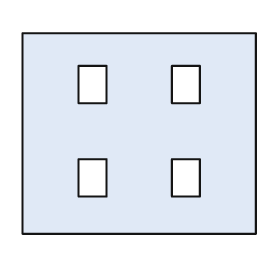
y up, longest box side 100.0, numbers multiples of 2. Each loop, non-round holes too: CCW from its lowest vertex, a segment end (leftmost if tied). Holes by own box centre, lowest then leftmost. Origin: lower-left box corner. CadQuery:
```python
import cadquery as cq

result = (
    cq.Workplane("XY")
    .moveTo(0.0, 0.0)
    .lineTo(100.0, 0.0)
    .lineTo(100.0, 86.0)
    .lineTo(0.0, 86.0)
    .close()
    .moveTo(24.0, 16.0)
    .lineTo(36.0, 16.0)
    .lineTo(36.0, 32.0)
    .lineTo(24.0, 32.0)
    .close()
    .moveTo(64.0, 16.0)
    .lineTo(76.0, 16.0)
    .lineTo(76.0, 32.0)
    .lineTo(64.0, 32.0)
    .close()
    .moveTo(24.0, 56.0)
    .lineTo(36.0, 56.0)
    .lineTo(36.0, 72.0)
    .lineTo(24.0, 72.0)
    .close()
    .moveTo(64.0, 56.0)
    .lineTo(76.0, 56.0)
    .lineTo(76.0, 72.0)
    .lineTo(64.0, 72.0)
    .close()
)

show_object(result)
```